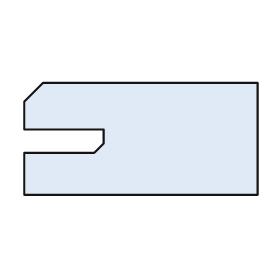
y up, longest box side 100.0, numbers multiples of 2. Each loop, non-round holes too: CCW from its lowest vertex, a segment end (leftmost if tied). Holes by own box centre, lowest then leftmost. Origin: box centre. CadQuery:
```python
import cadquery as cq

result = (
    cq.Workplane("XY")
    .moveTo(-50.0, -24.0)
    .lineTo(50.0, -24.0)
    .lineTo(50.0, 24.0)
    .lineTo(-42.0, 24.0)
    .lineTo(-50.0, 16.0)
    .lineTo(-50.0, 4.0)
    .lineTo(-16.0, 4.0)
    .lineTo(-16.0, -2.0)
    .lineTo(-20.0, -6.0)
    .lineTo(-50.0, -6.0)
    .close()
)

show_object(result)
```